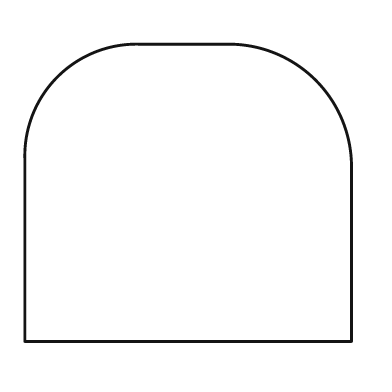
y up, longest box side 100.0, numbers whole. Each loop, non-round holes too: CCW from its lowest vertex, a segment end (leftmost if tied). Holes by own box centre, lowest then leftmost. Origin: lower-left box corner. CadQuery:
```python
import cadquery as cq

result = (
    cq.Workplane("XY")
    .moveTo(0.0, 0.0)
    .lineTo(100.0, 0.0)
    .lineTo(100.0, 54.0)
    .threePointArc((89.0, 80.0), (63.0, 91.0))
    .lineTo(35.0, 91.0)
    .threePointArc((10.0, 81.0), (0.0, 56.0))
    .close()
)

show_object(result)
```